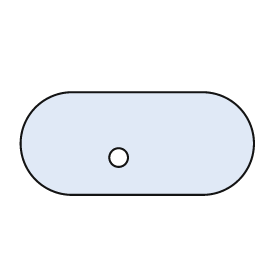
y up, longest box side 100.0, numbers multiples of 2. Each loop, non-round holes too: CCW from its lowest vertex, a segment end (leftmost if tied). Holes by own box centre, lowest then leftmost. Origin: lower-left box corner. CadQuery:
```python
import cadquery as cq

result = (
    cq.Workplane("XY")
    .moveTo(22.0, 0.0)
    .lineTo(78.0, 0.0)
    .threePointArc((100.0, 22.0), (78.0, 44.0))
    .lineTo(22.0, 44.0)
    .threePointArc((0.0, 22.0), (22.0, 0.0))
    .close()
    .moveTo(42.0, 16.0)
    .circle(4.0)
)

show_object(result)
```